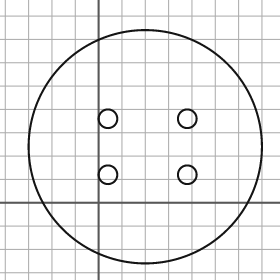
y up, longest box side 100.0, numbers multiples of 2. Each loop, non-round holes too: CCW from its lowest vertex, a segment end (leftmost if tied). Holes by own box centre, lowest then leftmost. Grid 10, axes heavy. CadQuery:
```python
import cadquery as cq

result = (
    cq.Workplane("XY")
    .moveTo(20.0, 24.0)
    .circle(50.0)
    .moveTo(4.0, 12.0)
    .circle(4.0)
    .moveTo(38.0, 12.0)
    .circle(4.0)
    .moveTo(4.0, 36.0)
    .circle(4.0)
    .moveTo(38.0, 36.0)
    .circle(4.0)
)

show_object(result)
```